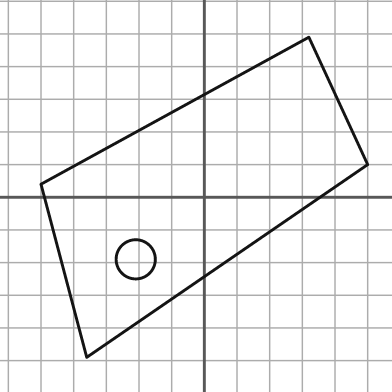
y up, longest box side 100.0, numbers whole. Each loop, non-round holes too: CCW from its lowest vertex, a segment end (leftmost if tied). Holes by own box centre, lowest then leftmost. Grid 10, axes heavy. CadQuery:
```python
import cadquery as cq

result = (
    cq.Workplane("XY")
    .moveTo(-36.0, -49.0)
    .lineTo(50.0, 10.0)
    .lineTo(32.0, 49.0)
    .lineTo(-50.0, 4.0)
    .close()
    .moveTo(-21.0, -19.0)
    .circle(6.0)
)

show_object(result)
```